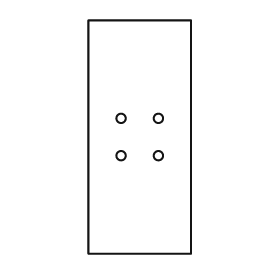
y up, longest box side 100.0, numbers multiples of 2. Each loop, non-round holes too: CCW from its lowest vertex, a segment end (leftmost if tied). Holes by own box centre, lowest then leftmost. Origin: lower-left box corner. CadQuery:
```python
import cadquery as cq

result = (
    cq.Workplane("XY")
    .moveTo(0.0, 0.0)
    .lineTo(44.0, 0.0)
    .lineTo(44.0, 100.0)
    .lineTo(0.0, 100.0)
    .close()
    .moveTo(14.0, 42.0)
    .circle(2.0)
    .moveTo(30.0, 42.0)
    .circle(2.0)
    .moveTo(14.0, 58.0)
    .circle(2.0)
    .moveTo(30.0, 58.0)
    .circle(2.0)
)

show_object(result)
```